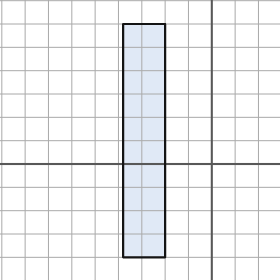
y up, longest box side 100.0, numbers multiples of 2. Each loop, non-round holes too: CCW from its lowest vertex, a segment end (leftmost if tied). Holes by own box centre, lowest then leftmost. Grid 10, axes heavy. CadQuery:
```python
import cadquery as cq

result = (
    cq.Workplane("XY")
    .moveTo(-38.0, -40.0)
    .lineTo(-20.0, -40.0)
    .lineTo(-20.0, 60.0)
    .lineTo(-38.0, 60.0)
    .close()
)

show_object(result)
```